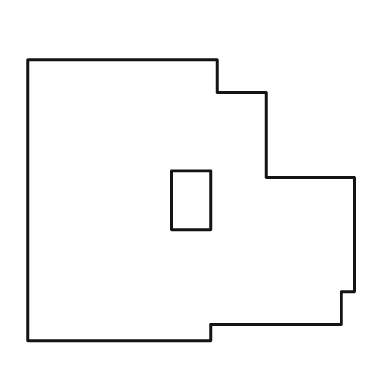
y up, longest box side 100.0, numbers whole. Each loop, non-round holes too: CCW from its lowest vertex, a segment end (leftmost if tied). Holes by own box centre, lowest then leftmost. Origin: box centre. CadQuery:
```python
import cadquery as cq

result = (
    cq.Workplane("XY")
    .moveTo(-50.0, -43.0)
    .lineTo(6.0, -43.0)
    .lineTo(6.0, -38.0)
    .lineTo(46.0, -38.0)
    .lineTo(46.0, -28.0)
    .lineTo(50.0, -28.0)
    .lineTo(50.0, 7.0)
    .lineTo(23.0, 7.0)
    .lineTo(23.0, 33.0)
    .lineTo(8.0, 33.0)
    .lineTo(8.0, 43.0)
    .lineTo(-50.0, 43.0)
    .close()
    .moveTo(-6.0, -9.0)
    .lineTo(6.0, -9.0)
    .lineTo(6.0, 9.0)
    .lineTo(-6.0, 9.0)
    .close()
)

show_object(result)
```